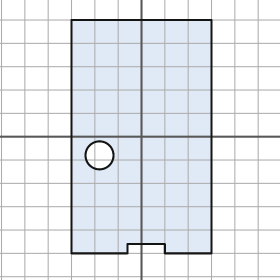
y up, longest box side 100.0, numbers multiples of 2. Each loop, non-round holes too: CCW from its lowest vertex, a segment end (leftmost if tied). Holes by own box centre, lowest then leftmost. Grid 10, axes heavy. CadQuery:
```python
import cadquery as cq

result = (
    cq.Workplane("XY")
    .moveTo(-30.0, -50.0)
    .lineTo(-6.0, -50.0)
    .lineTo(-6.0, -46.0)
    .lineTo(10.0, -46.0)
    .lineTo(10.0, -50.0)
    .lineTo(30.0, -50.0)
    .lineTo(30.0, 50.0)
    .lineTo(-30.0, 50.0)
    .close()
    .moveTo(-18.0, -8.0)
    .circle(6.0)
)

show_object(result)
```